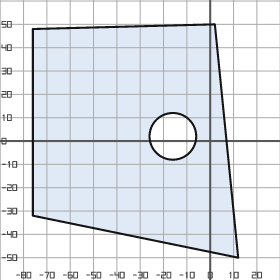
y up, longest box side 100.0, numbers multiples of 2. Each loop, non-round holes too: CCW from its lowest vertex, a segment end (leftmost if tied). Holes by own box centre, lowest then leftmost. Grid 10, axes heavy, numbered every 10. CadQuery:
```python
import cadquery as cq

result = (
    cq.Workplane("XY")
    .moveTo(12.0, -50.0)
    .lineTo(2.0, 50.0)
    .lineTo(-76.0, 48.0)
    .lineTo(-76.0, -32.0)
    .close()
    .moveTo(-16.0, 2.0)
    .circle(10.0)
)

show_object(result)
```